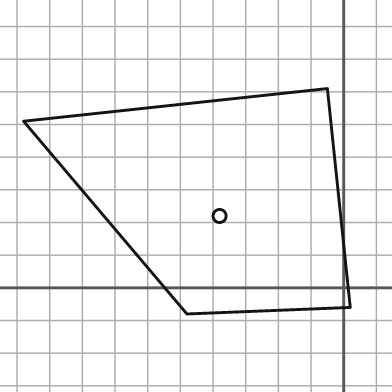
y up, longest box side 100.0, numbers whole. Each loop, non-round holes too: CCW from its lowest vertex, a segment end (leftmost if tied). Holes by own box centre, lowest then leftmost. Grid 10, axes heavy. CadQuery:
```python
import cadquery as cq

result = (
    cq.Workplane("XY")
    .moveTo(-48.0, -8.0)
    .lineTo(2.0, -6.0)
    .lineTo(-5.0, 61.0)
    .lineTo(-98.0, 51.0)
    .close()
    .moveTo(-38.0, 22.0)
    .circle(2.0)
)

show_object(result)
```